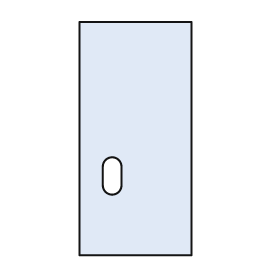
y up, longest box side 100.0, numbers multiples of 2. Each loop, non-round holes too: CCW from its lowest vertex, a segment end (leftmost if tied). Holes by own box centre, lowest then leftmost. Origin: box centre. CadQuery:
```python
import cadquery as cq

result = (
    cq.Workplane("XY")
    .moveTo(-24.0, -50.0)
    .lineTo(24.0, -50.0)
    .lineTo(24.0, 50.0)
    .lineTo(-24.0, 50.0)
    .close()
    .moveTo(-14.0, -20.0)
    .threePointArc((-10.0, -24.0), (-6.0, -20.0))
    .lineTo(-6.0, -12.0)
    .threePointArc((-10.0, -8.0), (-14.0, -12.0))
    .close()
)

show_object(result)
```